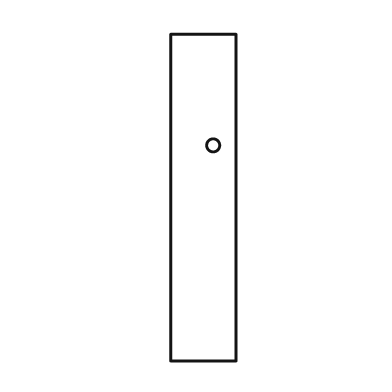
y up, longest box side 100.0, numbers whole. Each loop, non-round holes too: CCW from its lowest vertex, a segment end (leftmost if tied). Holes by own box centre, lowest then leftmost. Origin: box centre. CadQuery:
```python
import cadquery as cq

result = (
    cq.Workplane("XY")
    .moveTo(-10.0, -50.0)
    .lineTo(10.0, -50.0)
    .lineTo(10.0, 50.0)
    .lineTo(-10.0, 50.0)
    .close()
    .moveTo(3.0, 16.0)
    .circle(2.0)
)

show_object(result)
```